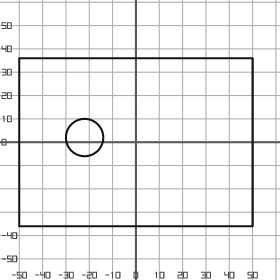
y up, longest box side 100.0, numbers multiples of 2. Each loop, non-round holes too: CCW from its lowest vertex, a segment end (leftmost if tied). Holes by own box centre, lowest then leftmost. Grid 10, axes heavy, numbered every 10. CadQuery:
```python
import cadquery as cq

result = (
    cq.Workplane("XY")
    .moveTo(-50.0, -36.0)
    .lineTo(50.0, -36.0)
    .lineTo(50.0, 36.0)
    .lineTo(-50.0, 36.0)
    .close()
    .moveTo(-22.0, 2.0)
    .circle(8.0)
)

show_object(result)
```